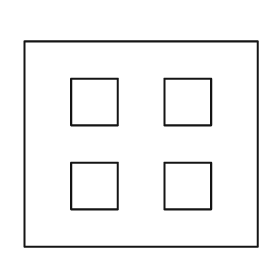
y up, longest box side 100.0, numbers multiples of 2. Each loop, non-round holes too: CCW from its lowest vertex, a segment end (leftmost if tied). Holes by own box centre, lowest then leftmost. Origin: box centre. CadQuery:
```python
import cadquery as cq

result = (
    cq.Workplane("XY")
    .moveTo(-50.0, -44.0)
    .lineTo(50.0, -44.0)
    .lineTo(50.0, 44.0)
    .lineTo(-50.0, 44.0)
    .close()
    .moveTo(-30.0, -28.0)
    .lineTo(-10.0, -28.0)
    .lineTo(-10.0, -8.0)
    .lineTo(-30.0, -8.0)
    .close()
    .moveTo(10.0, -28.0)
    .lineTo(30.0, -28.0)
    .lineTo(30.0, -8.0)
    .lineTo(10.0, -8.0)
    .close()
    .moveTo(-30.0, 8.0)
    .lineTo(-10.0, 8.0)
    .lineTo(-10.0, 28.0)
    .lineTo(-30.0, 28.0)
    .close()
    .moveTo(10.0, 8.0)
    .lineTo(30.0, 8.0)
    .lineTo(30.0, 28.0)
    .lineTo(10.0, 28.0)
    .close()
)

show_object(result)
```